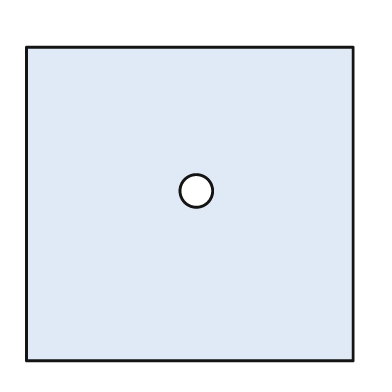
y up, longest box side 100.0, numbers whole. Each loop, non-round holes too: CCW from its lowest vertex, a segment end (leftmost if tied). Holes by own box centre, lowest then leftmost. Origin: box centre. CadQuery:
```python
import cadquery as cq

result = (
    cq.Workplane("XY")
    .moveTo(-50.0, -48.0)
    .lineTo(50.0, -48.0)
    .lineTo(50.0, 48.0)
    .lineTo(-50.0, 48.0)
    .close()
    .moveTo(2.0, 4.0)
    .circle(5.0)
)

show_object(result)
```